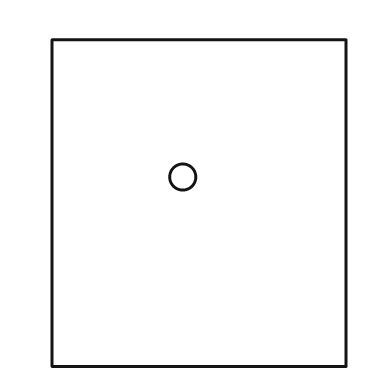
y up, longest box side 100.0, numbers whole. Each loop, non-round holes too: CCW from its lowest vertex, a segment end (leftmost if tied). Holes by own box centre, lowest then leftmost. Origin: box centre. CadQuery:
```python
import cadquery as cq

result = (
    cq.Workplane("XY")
    .moveTo(-45.0, -50.0)
    .lineTo(45.0, -50.0)
    .lineTo(45.0, 50.0)
    .lineTo(-45.0, 50.0)
    .close()
    .moveTo(-5.0, 8.0)
    .circle(4.0)
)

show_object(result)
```